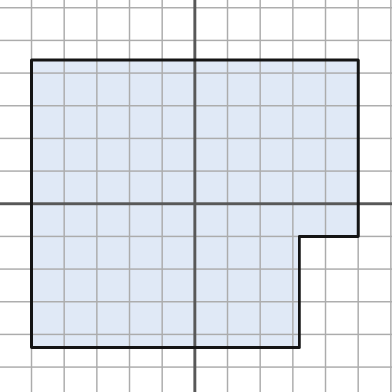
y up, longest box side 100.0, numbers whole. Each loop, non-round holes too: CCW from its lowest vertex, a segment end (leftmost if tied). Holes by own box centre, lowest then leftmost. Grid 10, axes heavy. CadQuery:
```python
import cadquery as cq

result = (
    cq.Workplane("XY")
    .moveTo(-50.0, -44.0)
    .lineTo(32.0, -44.0)
    .lineTo(32.0, -10.0)
    .lineTo(50.0, -10.0)
    .lineTo(50.0, 44.0)
    .lineTo(-50.0, 44.0)
    .close()
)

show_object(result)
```